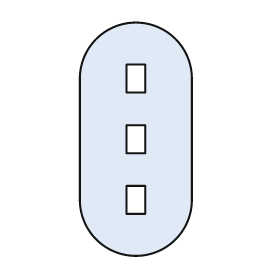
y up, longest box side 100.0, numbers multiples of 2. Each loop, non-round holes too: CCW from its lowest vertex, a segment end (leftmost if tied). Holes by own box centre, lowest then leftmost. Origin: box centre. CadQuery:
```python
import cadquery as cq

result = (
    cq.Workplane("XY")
    .moveTo(-24.0, -26.0)
    .threePointArc((0.0, -50.0), (24.0, -26.0))
    .lineTo(24.0, 26.0)
    .threePointArc((0.0, 50.0), (-24.0, 26.0))
    .close()
    .moveTo(-4.0, -32.0)
    .lineTo(4.0, -32.0)
    .lineTo(4.0, -20.0)
    .lineTo(-4.0, -20.0)
    .close()
    .moveTo(-4.0, -6.0)
    .lineTo(4.0, -6.0)
    .lineTo(4.0, 6.0)
    .lineTo(-4.0, 6.0)
    .close()
    .moveTo(-4.0, 20.0)
    .lineTo(4.0, 20.0)
    .lineTo(4.0, 32.0)
    .lineTo(-4.0, 32.0)
    .close()
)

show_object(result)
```